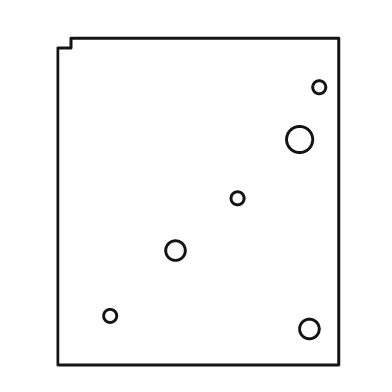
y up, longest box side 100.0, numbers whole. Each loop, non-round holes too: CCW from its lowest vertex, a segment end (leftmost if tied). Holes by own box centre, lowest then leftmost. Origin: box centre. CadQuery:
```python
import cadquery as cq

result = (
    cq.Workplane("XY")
    .moveTo(-43.0, -50.0)
    .lineTo(43.0, -50.0)
    .lineTo(43.0, 50.0)
    .lineTo(-39.0, 50.0)
    .lineTo(-39.0, 47.0)
    .lineTo(-43.0, 47.0)
    .close()
    .moveTo(34.0, -39.0)
    .circle(3.0)
    .moveTo(-27.0, -35.0)
    .circle(2.0)
    .moveTo(-7.0, -15.0)
    .circle(3.0)
    .moveTo(12.0, 1.0)
    .circle(2.0)
    .moveTo(31.0, 19.0)
    .circle(4.0)
    .moveTo(37.0, 35.0)
    .circle(2.0)
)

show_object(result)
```